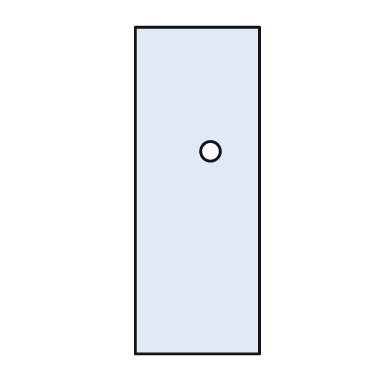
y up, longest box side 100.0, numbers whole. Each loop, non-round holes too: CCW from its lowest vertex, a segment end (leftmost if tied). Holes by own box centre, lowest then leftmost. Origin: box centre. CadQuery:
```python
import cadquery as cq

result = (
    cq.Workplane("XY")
    .moveTo(-19.0, -50.0)
    .lineTo(19.0, -50.0)
    .lineTo(19.0, 50.0)
    .lineTo(-19.0, 50.0)
    .close()
    .moveTo(4.0, 12.0)
    .circle(3.0)
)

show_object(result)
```